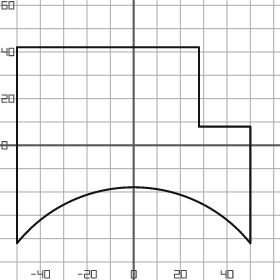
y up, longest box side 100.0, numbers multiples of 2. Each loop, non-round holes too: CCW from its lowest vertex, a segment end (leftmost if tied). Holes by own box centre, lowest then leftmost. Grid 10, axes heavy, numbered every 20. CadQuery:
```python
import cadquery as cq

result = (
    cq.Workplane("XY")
    .moveTo(-50.0, -42.0)
    .threePointArc((0.0, -18.0), (50.0, -42.0))
    .lineTo(50.0, 8.0)
    .lineTo(28.0, 8.0)
    .lineTo(28.0, 42.0)
    .lineTo(-50.0, 42.0)
    .close()
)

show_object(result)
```